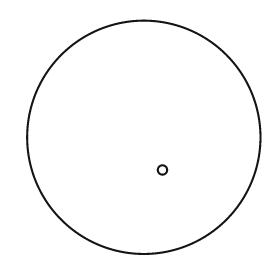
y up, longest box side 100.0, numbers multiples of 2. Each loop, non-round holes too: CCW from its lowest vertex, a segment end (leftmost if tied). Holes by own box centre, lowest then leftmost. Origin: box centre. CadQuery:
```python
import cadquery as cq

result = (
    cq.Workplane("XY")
    .moveTo(0.0, 0.0)
    .circle(50.0)
    .moveTo(8.0, -14.0)
    .circle(2.0)
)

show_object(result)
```